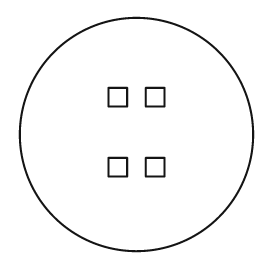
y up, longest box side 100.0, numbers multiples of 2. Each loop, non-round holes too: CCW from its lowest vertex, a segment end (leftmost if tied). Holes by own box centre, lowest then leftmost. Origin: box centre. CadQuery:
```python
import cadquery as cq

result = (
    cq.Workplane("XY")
    .moveTo(0.0, 0.0)
    .circle(50.0)
    .moveTo(-12.0, -18.0)
    .lineTo(-4.0, -18.0)
    .lineTo(-4.0, -10.0)
    .lineTo(-12.0, -10.0)
    .close()
    .moveTo(4.0, -18.0)
    .lineTo(12.0, -18.0)
    .lineTo(12.0, -10.0)
    .lineTo(4.0, -10.0)
    .close()
    .moveTo(-12.0, 12.0)
    .lineTo(-4.0, 12.0)
    .lineTo(-4.0, 20.0)
    .lineTo(-12.0, 20.0)
    .close()
    .moveTo(4.0, 12.0)
    .lineTo(12.0, 12.0)
    .lineTo(12.0, 20.0)
    .lineTo(4.0, 20.0)
    .close()
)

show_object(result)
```